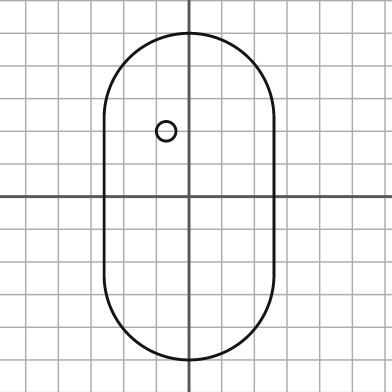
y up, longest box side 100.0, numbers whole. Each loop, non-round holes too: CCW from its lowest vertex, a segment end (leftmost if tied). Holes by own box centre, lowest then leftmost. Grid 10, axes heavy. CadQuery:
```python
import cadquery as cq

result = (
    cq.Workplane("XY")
    .moveTo(-26.0, -24.0)
    .threePointArc((0.0, -50.0), (26.0, -24.0))
    .lineTo(26.0, 24.0)
    .threePointArc((0.0, 50.0), (-26.0, 24.0))
    .close()
    .moveTo(-7.0, 20.0)
    .circle(3.0)
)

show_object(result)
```